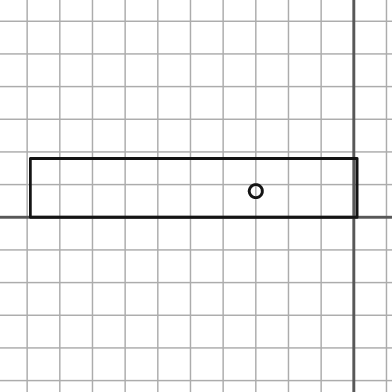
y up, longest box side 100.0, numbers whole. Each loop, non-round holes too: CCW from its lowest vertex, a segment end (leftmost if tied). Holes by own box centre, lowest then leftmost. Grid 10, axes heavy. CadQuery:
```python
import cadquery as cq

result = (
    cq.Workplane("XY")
    .moveTo(-99.0, 0.0)
    .lineTo(1.0, 0.0)
    .lineTo(1.0, 18.0)
    .lineTo(-99.0, 18.0)
    .close()
    .moveTo(-30.0, 8.0)
    .circle(2.0)
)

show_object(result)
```